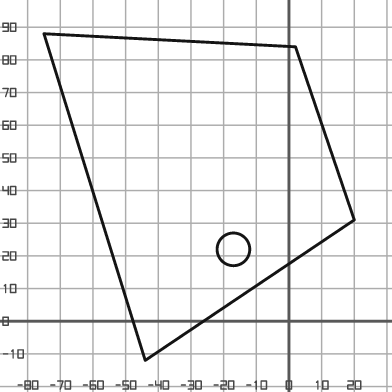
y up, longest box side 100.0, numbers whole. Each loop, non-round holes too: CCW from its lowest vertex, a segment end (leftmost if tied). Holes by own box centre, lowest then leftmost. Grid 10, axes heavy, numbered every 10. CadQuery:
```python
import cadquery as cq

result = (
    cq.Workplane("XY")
    .moveTo(-44.0, -12.0)
    .lineTo(20.0, 31.0)
    .lineTo(2.0, 84.0)
    .lineTo(-75.0, 88.0)
    .close()
    .moveTo(-17.0, 22.0)
    .circle(5.0)
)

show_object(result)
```